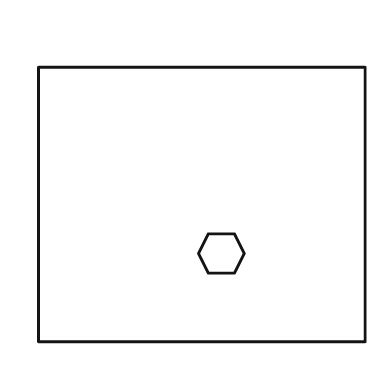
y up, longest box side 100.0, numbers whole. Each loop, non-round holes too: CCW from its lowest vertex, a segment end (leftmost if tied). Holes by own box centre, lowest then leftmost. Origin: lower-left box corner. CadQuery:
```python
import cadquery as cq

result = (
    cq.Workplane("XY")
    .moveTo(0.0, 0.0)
    .lineTo(100.0, 0.0)
    .lineTo(100.0, 84.0)
    .lineTo(0.0, 84.0)
    .close()
    .moveTo(52.0, 21.0)
    .lineTo(60.0, 21.0)
    .lineTo(63.0, 27.0)
    .lineTo(60.0, 33.0)
    .lineTo(52.0, 33.0)
    .lineTo(49.0, 27.0)
    .close()
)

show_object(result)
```